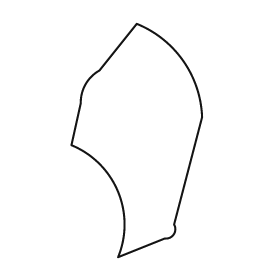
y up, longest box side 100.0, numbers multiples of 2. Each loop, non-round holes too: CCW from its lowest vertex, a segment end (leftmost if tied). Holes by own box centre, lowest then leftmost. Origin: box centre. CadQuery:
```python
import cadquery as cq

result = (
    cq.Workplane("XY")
    .moveTo(-8.0, -50.0)
    .lineTo(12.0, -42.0)
    .threePointArc((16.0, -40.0), (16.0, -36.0))
    .lineTo(28.0, 10.0)
    .threePointArc((20.0, 34.0), (0.0, 50.0))
    .lineTo(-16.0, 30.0)
    .threePointArc((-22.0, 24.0), (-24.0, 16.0))
    .lineTo(-28.0, -2.0)
    .threePointArc((-8.0, -22.0), (-8.0, -50.0))
    .close()
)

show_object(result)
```